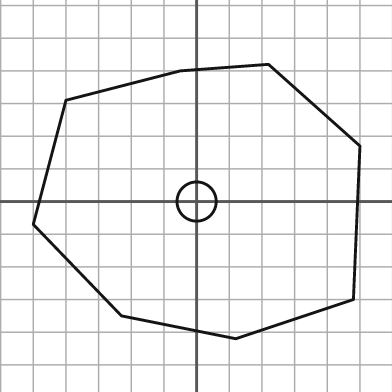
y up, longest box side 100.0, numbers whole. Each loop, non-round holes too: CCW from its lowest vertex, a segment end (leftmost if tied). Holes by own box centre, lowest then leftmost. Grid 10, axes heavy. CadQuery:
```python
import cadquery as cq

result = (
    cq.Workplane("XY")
    .moveTo(12.0, -42.0)
    .lineTo(48.0, -30.0)
    .lineTo(50.0, 17.0)
    .lineTo(22.0, 42.0)
    .lineTo(-5.0, 40.0)
    .lineTo(-40.0, 31.0)
    .lineTo(-50.0, -7.0)
    .lineTo(-23.0, -35.0)
    .close()
    .moveTo(0.0, 0.0)
    .circle(6.0)
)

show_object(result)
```